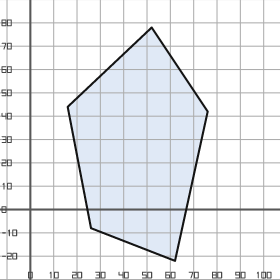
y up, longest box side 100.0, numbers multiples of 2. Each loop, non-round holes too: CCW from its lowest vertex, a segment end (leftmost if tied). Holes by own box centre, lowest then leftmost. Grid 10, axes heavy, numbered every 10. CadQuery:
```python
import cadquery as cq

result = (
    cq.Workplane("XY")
    .moveTo(62.0, -22.0)
    .lineTo(76.0, 42.0)
    .lineTo(52.0, 78.0)
    .lineTo(16.0, 44.0)
    .lineTo(26.0, -8.0)
    .close()
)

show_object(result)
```